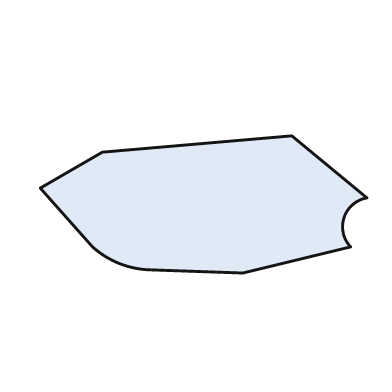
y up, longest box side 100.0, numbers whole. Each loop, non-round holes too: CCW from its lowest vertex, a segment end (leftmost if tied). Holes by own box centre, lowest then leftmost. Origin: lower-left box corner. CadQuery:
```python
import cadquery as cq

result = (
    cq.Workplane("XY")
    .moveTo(62.0, 0.0)
    .lineTo(95.0, 8.0)
    .threePointArc((93.0, 17.0), (100.0, 23.0))
    .lineTo(77.0, 42.0)
    .lineTo(19.0, 37.0)
    .lineTo(0.0, 26.0)
    .lineTo(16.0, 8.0)
    .threePointArc((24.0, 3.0), (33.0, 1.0))
    .close()
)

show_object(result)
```